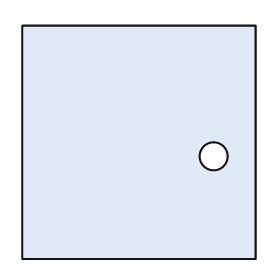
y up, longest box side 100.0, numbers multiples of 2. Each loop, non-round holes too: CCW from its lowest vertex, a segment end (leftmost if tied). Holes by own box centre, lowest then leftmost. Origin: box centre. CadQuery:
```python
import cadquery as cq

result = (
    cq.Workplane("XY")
    .moveTo(-50.0, -50.0)
    .lineTo(50.0, -50.0)
    .lineTo(50.0, 50.0)
    .lineTo(-50.0, 50.0)
    .close()
    .moveTo(32.0, -6.0)
    .circle(6.0)
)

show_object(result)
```